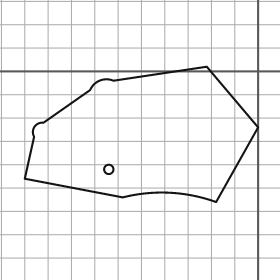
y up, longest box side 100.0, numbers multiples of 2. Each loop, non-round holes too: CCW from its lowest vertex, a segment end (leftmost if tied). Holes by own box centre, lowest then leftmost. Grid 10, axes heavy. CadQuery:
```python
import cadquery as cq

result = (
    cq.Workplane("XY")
    .moveTo(-18.0, -56.0)
    .lineTo(0.0, -24.0)
    .lineTo(-22.0, 2.0)
    .lineTo(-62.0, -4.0)
    .threePointArc((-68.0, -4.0), (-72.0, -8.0))
    .lineTo(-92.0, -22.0)
    .threePointArc((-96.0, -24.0), (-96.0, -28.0))
    .lineTo(-100.0, -46.0)
    .lineTo(-58.0, -54.0)
    .threePointArc((-38.0, -52.0), (-18.0, -56.0))
    .close()
    .moveTo(-64.0, -42.0)
    .circle(2.0)
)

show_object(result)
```